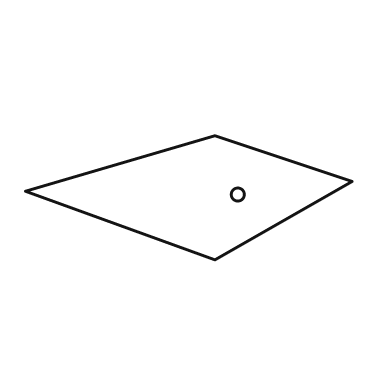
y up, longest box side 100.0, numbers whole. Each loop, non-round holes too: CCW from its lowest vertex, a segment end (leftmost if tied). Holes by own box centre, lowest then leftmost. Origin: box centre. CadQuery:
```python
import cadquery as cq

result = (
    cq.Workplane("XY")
    .moveTo(8.0, -19.0)
    .lineTo(50.0, 5.0)
    .lineTo(8.0, 19.0)
    .lineTo(-50.0, 2.0)
    .close()
    .moveTo(15.0, 1.0)
    .circle(2.0)
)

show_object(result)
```